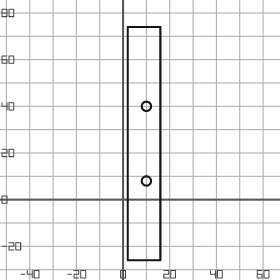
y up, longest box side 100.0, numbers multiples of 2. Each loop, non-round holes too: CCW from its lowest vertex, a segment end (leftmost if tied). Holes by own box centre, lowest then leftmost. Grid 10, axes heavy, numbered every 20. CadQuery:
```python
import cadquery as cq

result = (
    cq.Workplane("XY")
    .moveTo(2.0, -26.0)
    .lineTo(16.0, -26.0)
    .lineTo(16.0, 74.0)
    .lineTo(2.0, 74.0)
    .close()
    .moveTo(10.0, 8.0)
    .circle(2.0)
    .moveTo(10.0, 40.0)
    .circle(2.0)
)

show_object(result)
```